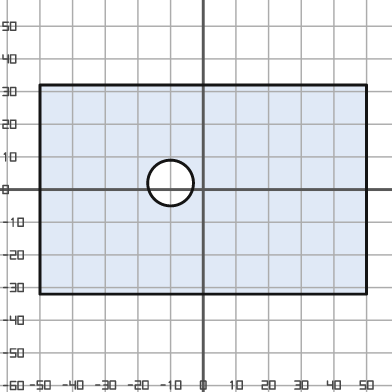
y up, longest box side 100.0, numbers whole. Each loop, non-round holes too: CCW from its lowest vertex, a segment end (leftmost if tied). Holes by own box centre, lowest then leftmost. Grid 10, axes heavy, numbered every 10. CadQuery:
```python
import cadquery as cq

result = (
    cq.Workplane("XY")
    .moveTo(-50.0, -32.0)
    .lineTo(50.0, -32.0)
    .lineTo(50.0, 32.0)
    .lineTo(-50.0, 32.0)
    .close()
    .moveTo(-10.0, 2.0)
    .circle(7.0)
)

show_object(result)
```